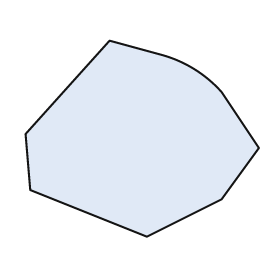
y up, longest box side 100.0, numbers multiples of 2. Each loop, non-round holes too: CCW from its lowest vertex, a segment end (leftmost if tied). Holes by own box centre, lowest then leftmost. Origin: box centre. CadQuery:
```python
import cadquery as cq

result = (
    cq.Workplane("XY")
    .moveTo(2.0, -42.0)
    .lineTo(34.0, -26.0)
    .lineTo(50.0, -4.0)
    .lineTo(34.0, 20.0)
    .threePointArc((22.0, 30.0), (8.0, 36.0))
    .lineTo(-14.0, 42.0)
    .lineTo(-50.0, 2.0)
    .lineTo(-48.0, -22.0)
    .close()
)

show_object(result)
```